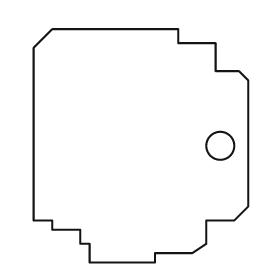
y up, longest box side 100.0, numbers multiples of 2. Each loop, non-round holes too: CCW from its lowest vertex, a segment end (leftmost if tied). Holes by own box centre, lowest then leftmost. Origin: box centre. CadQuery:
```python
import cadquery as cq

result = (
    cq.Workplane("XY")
    .moveTo(-22.0, -50.0)
    .lineTo(6.0, -50.0)
    .lineTo(6.0, -46.0)
    .lineTo(22.0, -46.0)
    .lineTo(28.0, -42.0)
    .lineTo(28.0, -32.0)
    .lineTo(40.0, -32.0)
    .lineTo(46.0, -26.0)
    .lineTo(46.0, 28.0)
    .lineTo(42.0, 32.0)
    .lineTo(32.0, 32.0)
    .lineTo(32.0, 44.0)
    .lineTo(16.0, 44.0)
    .lineTo(16.0, 50.0)
    .lineTo(-38.0, 50.0)
    .lineTo(-46.0, 42.0)
    .lineTo(-46.0, -32.0)
    .lineTo(-38.0, -32.0)
    .lineTo(-38.0, -36.0)
    .lineTo(-26.0, -36.0)
    .lineTo(-26.0, -42.0)
    .lineTo(-22.0, -42.0)
    .close()
    .moveTo(34.0, 0.0)
    .circle(6.0)
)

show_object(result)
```